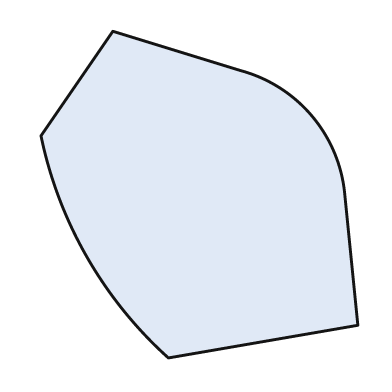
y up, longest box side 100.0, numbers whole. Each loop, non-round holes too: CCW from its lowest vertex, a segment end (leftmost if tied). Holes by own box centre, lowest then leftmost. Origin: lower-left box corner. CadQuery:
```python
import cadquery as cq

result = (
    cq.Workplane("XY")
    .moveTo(39.0, 0.0)
    .lineTo(97.0, 10.0)
    .lineTo(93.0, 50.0)
    .threePointArc((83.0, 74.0), (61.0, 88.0))
    .lineTo(22.0, 100.0)
    .lineTo(0.0, 68.0)
    .threePointArc((14.0, 31.0), (39.0, 0.0))
    .close()
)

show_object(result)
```